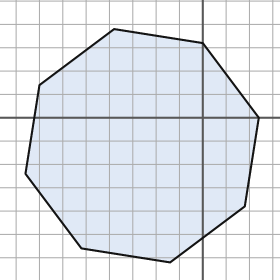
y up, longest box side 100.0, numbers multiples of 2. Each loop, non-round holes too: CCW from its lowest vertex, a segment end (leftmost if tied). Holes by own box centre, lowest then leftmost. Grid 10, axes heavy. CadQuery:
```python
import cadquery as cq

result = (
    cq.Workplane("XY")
    .moveTo(-14.0, -62.0)
    .lineTo(18.0, -38.0)
    .lineTo(24.0, 0.0)
    .lineTo(0.0, 32.0)
    .lineTo(-38.0, 38.0)
    .lineTo(-70.0, 14.0)
    .lineTo(-76.0, -24.0)
    .lineTo(-52.0, -56.0)
    .close()
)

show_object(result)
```